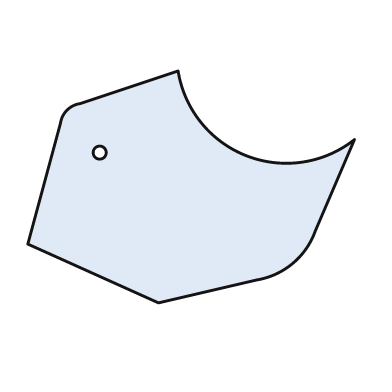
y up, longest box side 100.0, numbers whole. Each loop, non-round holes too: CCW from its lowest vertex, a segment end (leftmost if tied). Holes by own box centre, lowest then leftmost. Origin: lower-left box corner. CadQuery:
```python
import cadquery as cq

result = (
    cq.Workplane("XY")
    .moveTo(40.0, 0.0)
    .lineTo(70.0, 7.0)
    .threePointArc((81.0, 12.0), (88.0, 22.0))
    .lineTo(100.0, 50.0)
    .threePointArc((67.0, 45.0), (46.0, 71.0))
    .lineTo(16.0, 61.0)
    .threePointArc((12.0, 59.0), (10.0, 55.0))
    .lineTo(0.0, 18.0)
    .close()
    .moveTo(22.0, 46.0)
    .circle(2.0)
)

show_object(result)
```